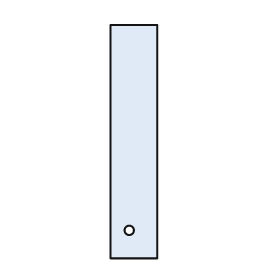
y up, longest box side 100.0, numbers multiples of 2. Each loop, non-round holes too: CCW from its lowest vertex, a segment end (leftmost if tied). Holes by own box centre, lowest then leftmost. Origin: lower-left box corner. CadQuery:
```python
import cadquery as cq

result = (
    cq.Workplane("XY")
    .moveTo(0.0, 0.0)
    .lineTo(20.0, 0.0)
    .lineTo(20.0, 100.0)
    .lineTo(0.0, 100.0)
    .close()
    .moveTo(8.0, 12.0)
    .circle(2.0)
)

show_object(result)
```